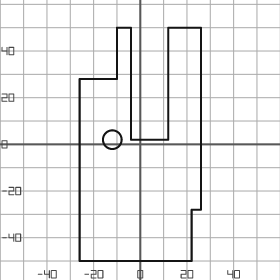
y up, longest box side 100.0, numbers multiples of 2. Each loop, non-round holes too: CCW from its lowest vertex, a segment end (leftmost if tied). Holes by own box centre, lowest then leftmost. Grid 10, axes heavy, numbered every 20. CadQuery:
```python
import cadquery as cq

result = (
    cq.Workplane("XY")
    .moveTo(-26.0, -50.0)
    .lineTo(22.0, -50.0)
    .lineTo(22.0, -28.0)
    .lineTo(26.0, -28.0)
    .lineTo(26.0, 50.0)
    .lineTo(12.0, 50.0)
    .lineTo(12.0, 2.0)
    .lineTo(-4.0, 2.0)
    .lineTo(-4.0, 50.0)
    .lineTo(-10.0, 50.0)
    .lineTo(-10.0, 28.0)
    .lineTo(-26.0, 28.0)
    .close()
    .moveTo(-12.0, 2.0)
    .circle(4.0)
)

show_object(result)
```